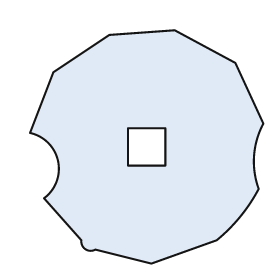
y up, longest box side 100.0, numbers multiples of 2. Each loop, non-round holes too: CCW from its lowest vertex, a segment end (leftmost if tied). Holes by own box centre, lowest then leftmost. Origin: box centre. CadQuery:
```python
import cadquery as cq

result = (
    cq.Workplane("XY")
    .moveTo(2.0, -50.0)
    .lineTo(30.0, -40.0)
    .threePointArc((40.0, -30.0), (48.0, -18.0))
    .threePointArc((46.0, -4.0), (50.0, 10.0))
    .lineTo(38.0, 36.0)
    .lineTo(12.0, 50.0)
    .lineTo(-16.0, 48.0)
    .lineTo(-40.0, 32.0)
    .lineTo(-50.0, 6.0)
    .threePointArc((-38.0, -6.0), (-44.0, -22.0))
    .lineTo(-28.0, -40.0)
    .threePointArc((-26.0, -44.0), (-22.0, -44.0))
    .close()
    .moveTo(-8.0, -8.0)
    .lineTo(8.0, -8.0)
    .lineTo(8.0, 8.0)
    .lineTo(-8.0, 8.0)
    .close()
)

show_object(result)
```